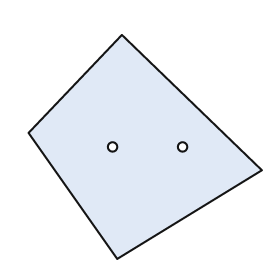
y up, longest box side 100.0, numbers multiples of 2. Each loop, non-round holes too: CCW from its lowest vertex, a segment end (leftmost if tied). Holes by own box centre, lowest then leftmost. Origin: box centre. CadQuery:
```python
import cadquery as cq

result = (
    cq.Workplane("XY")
    .moveTo(-12.0, -48.0)
    .lineTo(50.0, -10.0)
    .lineTo(-10.0, 48.0)
    .lineTo(-50.0, 6.0)
    .close()
    .moveTo(-14.0, 0.0)
    .circle(2.0)
    .moveTo(16.0, 0.0)
    .circle(2.0)
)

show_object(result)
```